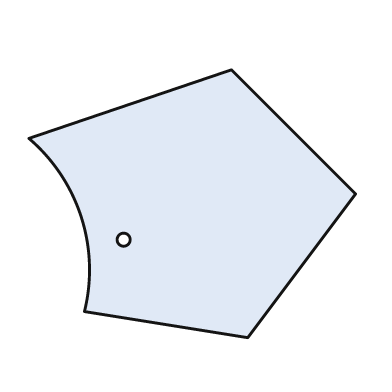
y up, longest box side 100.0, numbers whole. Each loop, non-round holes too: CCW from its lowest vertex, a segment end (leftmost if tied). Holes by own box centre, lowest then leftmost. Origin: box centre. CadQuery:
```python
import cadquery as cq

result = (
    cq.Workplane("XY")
    .moveTo(17.0, -41.0)
    .lineTo(50.0, 3.0)
    .lineTo(12.0, 41.0)
    .lineTo(-50.0, 20.0)
    .threePointArc((-34.0, -4.0), (-33.0, -33.0))
    .close()
    .moveTo(-21.0, -11.0)
    .circle(2.0)
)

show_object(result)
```